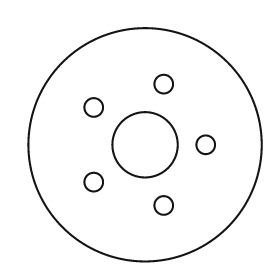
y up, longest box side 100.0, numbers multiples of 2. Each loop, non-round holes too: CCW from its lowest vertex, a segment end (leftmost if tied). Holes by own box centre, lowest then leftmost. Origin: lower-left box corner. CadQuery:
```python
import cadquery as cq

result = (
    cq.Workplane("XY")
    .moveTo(50.0, 50.0)
    .circle(50.0)
    .moveTo(58.0, 24.0)
    .circle(4.0)
    .moveTo(28.0, 34.0)
    .circle(4.0)
    .moveTo(50.0, 50.0)
    .circle(14.0)
    .moveTo(76.0, 50.0)
    .circle(4.0)
    .moveTo(28.0, 66.0)
    .circle(4.0)
    .moveTo(58.0, 76.0)
    .circle(4.0)
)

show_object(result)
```